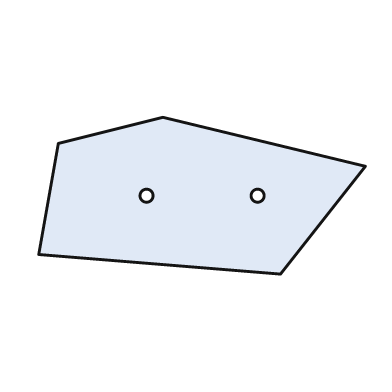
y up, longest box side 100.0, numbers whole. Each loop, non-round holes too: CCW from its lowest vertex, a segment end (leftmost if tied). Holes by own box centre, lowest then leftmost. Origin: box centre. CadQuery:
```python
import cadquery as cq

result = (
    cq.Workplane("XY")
    .moveTo(24.0, -24.0)
    .lineTo(50.0, 9.0)
    .lineTo(-12.0, 24.0)
    .lineTo(-44.0, 16.0)
    .lineTo(-50.0, -18.0)
    .close()
    .moveTo(-17.0, 0.0)
    .circle(2.0)
    .moveTo(17.0, 0.0)
    .circle(2.0)
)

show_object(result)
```